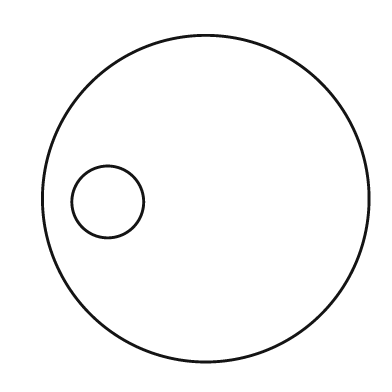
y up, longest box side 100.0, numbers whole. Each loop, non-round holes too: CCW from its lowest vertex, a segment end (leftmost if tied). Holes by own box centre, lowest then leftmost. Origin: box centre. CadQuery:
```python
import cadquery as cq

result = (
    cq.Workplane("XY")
    .moveTo(0.0, 0.0)
    .circle(50.0)
    .moveTo(-30.0, -1.0)
    .circle(11.0)
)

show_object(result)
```